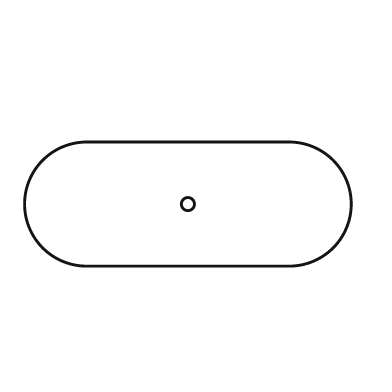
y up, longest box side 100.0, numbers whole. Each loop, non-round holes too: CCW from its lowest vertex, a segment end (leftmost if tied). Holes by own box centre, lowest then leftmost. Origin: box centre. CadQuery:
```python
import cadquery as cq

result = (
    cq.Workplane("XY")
    .moveTo(-31.0, -19.0)
    .lineTo(31.0, -19.0)
    .threePointArc((50.0, 0.0), (31.0, 19.0))
    .lineTo(-31.0, 19.0)
    .threePointArc((-50.0, 0.0), (-31.0, -19.0))
    .close()
    .moveTo(0.0, 0.0)
    .circle(2.0)
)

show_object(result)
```